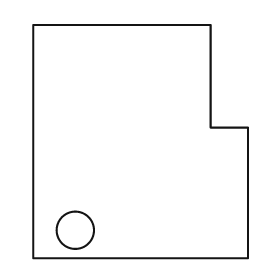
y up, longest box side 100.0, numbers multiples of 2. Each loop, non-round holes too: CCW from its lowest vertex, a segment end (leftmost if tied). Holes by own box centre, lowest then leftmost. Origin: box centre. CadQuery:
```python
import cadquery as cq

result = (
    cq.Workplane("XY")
    .moveTo(-46.0, -50.0)
    .lineTo(46.0, -50.0)
    .lineTo(46.0, 6.0)
    .lineTo(30.0, 6.0)
    .lineTo(30.0, 50.0)
    .lineTo(-46.0, 50.0)
    .close()
    .moveTo(-28.0, -38.0)
    .circle(8.0)
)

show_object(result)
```